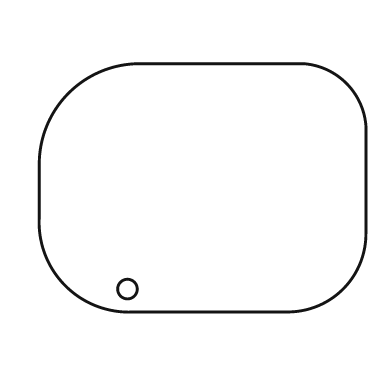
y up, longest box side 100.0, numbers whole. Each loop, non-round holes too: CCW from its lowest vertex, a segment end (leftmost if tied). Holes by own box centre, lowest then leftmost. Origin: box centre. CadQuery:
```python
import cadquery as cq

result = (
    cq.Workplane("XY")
    .moveTo(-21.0, -38.0)
    .lineTo(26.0, -38.0)
    .threePointArc((43.0, -31.0), (50.0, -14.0))
    .lineTo(50.0, 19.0)
    .threePointArc((44.0, 32.0), (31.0, 38.0))
    .lineTo(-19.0, 38.0)
    .threePointArc((-41.0, 29.0), (-50.0, 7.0))
    .lineTo(-50.0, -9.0)
    .threePointArc((-42.0, -30.0), (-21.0, -38.0))
    .close()
    .moveTo(-23.0, -31.0)
    .circle(3.0)
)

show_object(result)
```